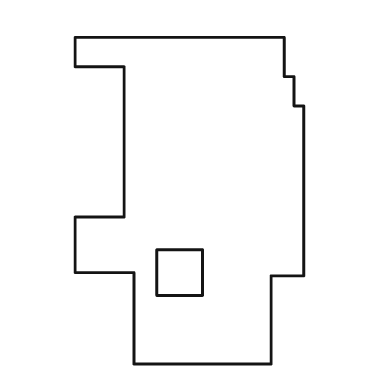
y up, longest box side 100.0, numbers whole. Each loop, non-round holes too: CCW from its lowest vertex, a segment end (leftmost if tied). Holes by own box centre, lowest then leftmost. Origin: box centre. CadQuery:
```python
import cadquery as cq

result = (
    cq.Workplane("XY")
    .moveTo(-17.0, -50.0)
    .lineTo(25.0, -50.0)
    .lineTo(25.0, -23.0)
    .lineTo(35.0, -23.0)
    .lineTo(35.0, 29.0)
    .lineTo(32.0, 29.0)
    .lineTo(32.0, 38.0)
    .lineTo(29.0, 38.0)
    .lineTo(29.0, 50.0)
    .lineTo(-35.0, 50.0)
    .lineTo(-35.0, 41.0)
    .lineTo(-20.0, 41.0)
    .lineTo(-20.0, -5.0)
    .lineTo(-35.0, -5.0)
    .lineTo(-35.0, -22.0)
    .lineTo(-17.0, -22.0)
    .close()
    .moveTo(-10.0, -29.0)
    .lineTo(4.0, -29.0)
    .lineTo(4.0, -15.0)
    .lineTo(-10.0, -15.0)
    .close()
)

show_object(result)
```